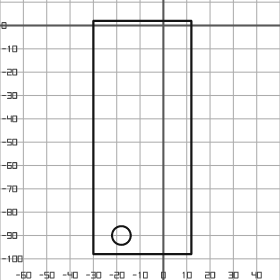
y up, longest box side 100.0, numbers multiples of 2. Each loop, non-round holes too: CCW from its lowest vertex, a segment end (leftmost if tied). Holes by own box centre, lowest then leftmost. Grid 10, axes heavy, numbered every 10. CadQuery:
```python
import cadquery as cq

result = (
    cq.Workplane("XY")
    .moveTo(-30.0, -98.0)
    .lineTo(12.0, -98.0)
    .lineTo(12.0, 2.0)
    .lineTo(-30.0, 2.0)
    .close()
    .moveTo(-18.0, -90.0)
    .circle(4.0)
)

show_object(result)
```